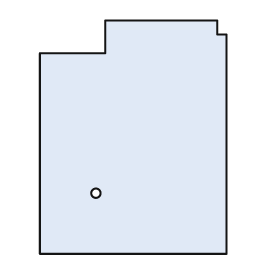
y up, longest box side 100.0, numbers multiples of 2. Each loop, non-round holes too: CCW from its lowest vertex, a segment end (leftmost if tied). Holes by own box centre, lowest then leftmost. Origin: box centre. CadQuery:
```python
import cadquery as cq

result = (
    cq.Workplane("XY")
    .moveTo(-40.0, -50.0)
    .lineTo(40.0, -50.0)
    .lineTo(40.0, 44.0)
    .lineTo(36.0, 44.0)
    .lineTo(36.0, 50.0)
    .lineTo(-12.0, 50.0)
    .lineTo(-12.0, 36.0)
    .lineTo(-40.0, 36.0)
    .close()
    .moveTo(-16.0, -24.0)
    .circle(2.0)
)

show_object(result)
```